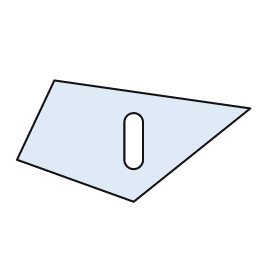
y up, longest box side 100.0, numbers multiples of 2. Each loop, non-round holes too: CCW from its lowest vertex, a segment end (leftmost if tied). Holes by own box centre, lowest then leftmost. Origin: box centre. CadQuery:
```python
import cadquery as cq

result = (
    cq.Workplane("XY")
    .moveTo(0.0, -26.0)
    .lineTo(50.0, 14.0)
    .lineTo(-34.0, 26.0)
    .lineTo(-50.0, -8.0)
    .close()
    .moveTo(-4.0, -8.0)
    .threePointArc((0.0, -12.0), (4.0, -8.0))
    .lineTo(4.0, 8.0)
    .threePointArc((0.0, 12.0), (-4.0, 8.0))
    .close()
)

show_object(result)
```